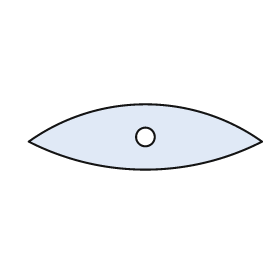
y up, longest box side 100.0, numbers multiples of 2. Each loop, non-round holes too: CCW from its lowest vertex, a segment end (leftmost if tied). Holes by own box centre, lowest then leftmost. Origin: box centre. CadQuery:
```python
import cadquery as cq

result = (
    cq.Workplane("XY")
    .moveTo(-50.0, -2.0)
    .threePointArc((0.0, -14.0), (50.0, -2.0))
    .threePointArc((0.0, 14.0), (-50.0, -2.0))
    .close()
    .moveTo(0.0, 0.0)
    .circle(4.0)
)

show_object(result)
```